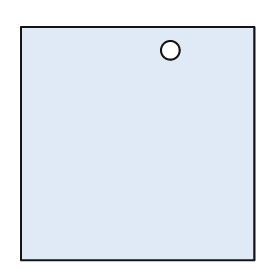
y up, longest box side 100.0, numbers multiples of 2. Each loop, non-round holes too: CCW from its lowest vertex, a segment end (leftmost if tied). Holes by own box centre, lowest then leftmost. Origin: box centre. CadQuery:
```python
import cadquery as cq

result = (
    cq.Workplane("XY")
    .moveTo(-50.0, -50.0)
    .lineTo(50.0, -50.0)
    .lineTo(50.0, 50.0)
    .lineTo(-50.0, 50.0)
    .close()
    .moveTo(14.0, 40.0)
    .circle(4.0)
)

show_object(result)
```